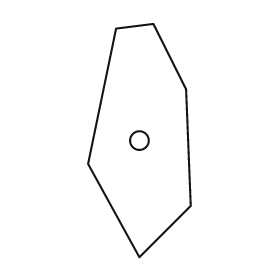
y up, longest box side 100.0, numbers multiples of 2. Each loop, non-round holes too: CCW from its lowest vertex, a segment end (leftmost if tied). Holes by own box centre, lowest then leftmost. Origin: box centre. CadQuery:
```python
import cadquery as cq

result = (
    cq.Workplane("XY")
    .moveTo(0.0, -50.0)
    .lineTo(22.0, -28.0)
    .lineTo(20.0, 22.0)
    .lineTo(6.0, 50.0)
    .lineTo(-10.0, 48.0)
    .lineTo(-22.0, -10.0)
    .close()
    .moveTo(0.0, 0.0)
    .circle(4.0)
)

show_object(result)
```